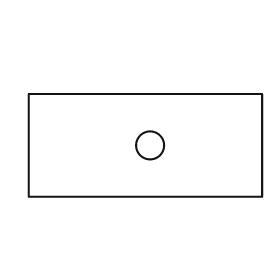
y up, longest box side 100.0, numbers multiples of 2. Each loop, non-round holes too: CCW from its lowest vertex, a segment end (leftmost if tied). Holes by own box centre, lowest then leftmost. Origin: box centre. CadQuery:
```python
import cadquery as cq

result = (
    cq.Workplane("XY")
    .moveTo(-50.0, -22.0)
    .lineTo(50.0, -22.0)
    .lineTo(50.0, 22.0)
    .lineTo(-50.0, 22.0)
    .close()
    .moveTo(2.0, 0.0)
    .circle(6.0)
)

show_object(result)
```